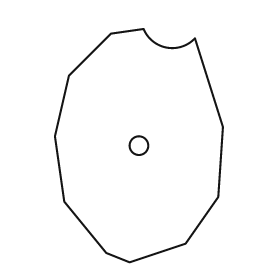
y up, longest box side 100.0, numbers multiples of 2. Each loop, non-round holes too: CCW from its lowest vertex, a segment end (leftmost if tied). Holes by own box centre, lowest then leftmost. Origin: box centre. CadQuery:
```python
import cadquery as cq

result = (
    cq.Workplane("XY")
    .moveTo(-4.0, -50.0)
    .lineTo(20.0, -42.0)
    .lineTo(34.0, -22.0)
    .lineTo(36.0, 8.0)
    .lineTo(24.0, 46.0)
    .threePointArc((12.0, 42.0), (2.0, 50.0))
    .lineTo(-12.0, 48.0)
    .lineTo(-30.0, 30.0)
    .lineTo(-36.0, 4.0)
    .lineTo(-32.0, -24.0)
    .lineTo(-14.0, -46.0)
    .close()
    .moveTo(0.0, 0.0)
    .circle(4.0)
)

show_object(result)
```